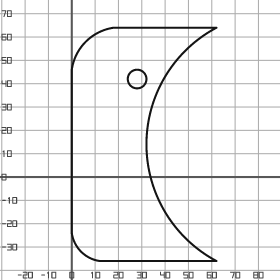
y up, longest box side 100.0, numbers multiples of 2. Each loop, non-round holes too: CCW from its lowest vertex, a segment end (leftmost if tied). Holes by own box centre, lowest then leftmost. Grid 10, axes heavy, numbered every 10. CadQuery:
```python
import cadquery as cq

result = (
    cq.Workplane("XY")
    .moveTo(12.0, -36.0)
    .lineTo(62.0, -36.0)
    .threePointArc((32.0, 14.0), (62.0, 64.0))
    .lineTo(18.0, 64.0)
    .threePointArc((6.0, 58.0), (0.0, 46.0))
    .lineTo(0.0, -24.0)
    .threePointArc((4.0, -32.0), (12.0, -36.0))
    .close()
    .moveTo(28.0, 42.0)
    .circle(4.0)
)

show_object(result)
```